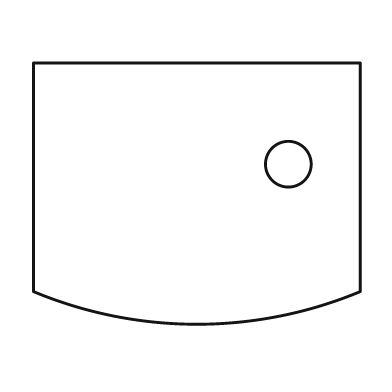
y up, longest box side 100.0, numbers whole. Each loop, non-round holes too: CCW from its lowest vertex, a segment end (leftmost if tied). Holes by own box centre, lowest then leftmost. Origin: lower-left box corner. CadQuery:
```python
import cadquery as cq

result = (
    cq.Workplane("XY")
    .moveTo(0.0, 10.0)
    .threePointArc((50.0, 0.0), (100.0, 10.0))
    .lineTo(100.0, 80.0)
    .lineTo(0.0, 80.0)
    .close()
    .moveTo(78.0, 49.0)
    .circle(7.0)
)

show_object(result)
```